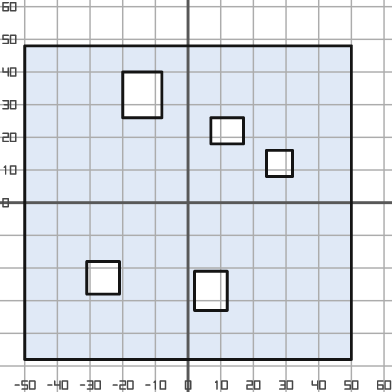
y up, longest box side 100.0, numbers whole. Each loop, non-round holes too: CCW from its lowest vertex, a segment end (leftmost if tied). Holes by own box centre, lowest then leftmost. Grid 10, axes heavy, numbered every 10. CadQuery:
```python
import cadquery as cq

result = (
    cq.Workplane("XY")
    .moveTo(-50.0, -48.0)
    .lineTo(50.0, -48.0)
    .lineTo(50.0, 48.0)
    .lineTo(-50.0, 48.0)
    .close()
    .moveTo(2.0, -33.0)
    .lineTo(12.0, -33.0)
    .lineTo(12.0, -21.0)
    .lineTo(2.0, -21.0)
    .close()
    .moveTo(-31.0, -28.0)
    .lineTo(-21.0, -28.0)
    .lineTo(-21.0, -18.0)
    .lineTo(-31.0, -18.0)
    .close()
    .moveTo(24.0, 8.0)
    .lineTo(32.0, 8.0)
    .lineTo(32.0, 16.0)
    .lineTo(24.0, 16.0)
    .close()
    .moveTo(7.0, 18.0)
    .lineTo(17.0, 18.0)
    .lineTo(17.0, 26.0)
    .lineTo(7.0, 26.0)
    .close()
    .moveTo(-20.0, 26.0)
    .lineTo(-8.0, 26.0)
    .lineTo(-8.0, 40.0)
    .lineTo(-20.0, 40.0)
    .close()
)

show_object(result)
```